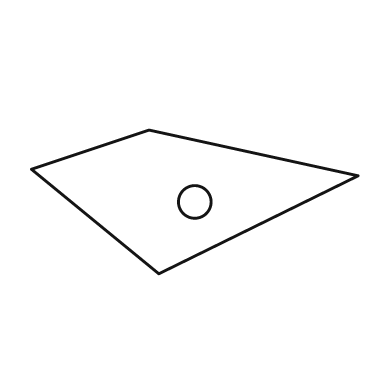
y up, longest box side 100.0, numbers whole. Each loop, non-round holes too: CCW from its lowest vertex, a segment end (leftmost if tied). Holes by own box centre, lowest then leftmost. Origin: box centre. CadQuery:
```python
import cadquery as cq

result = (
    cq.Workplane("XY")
    .moveTo(-11.0, -22.0)
    .lineTo(50.0, 8.0)
    .lineTo(-14.0, 22.0)
    .lineTo(-50.0, 10.0)
    .close()
    .moveTo(0.0, 0.0)
    .circle(5.0)
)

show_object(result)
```